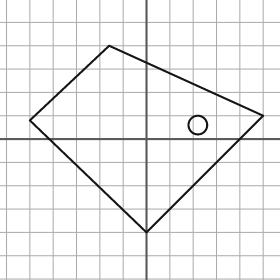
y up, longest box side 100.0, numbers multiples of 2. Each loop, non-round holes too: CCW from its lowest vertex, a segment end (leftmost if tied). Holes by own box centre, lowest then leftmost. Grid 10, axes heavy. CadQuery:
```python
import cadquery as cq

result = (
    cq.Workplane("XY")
    .moveTo(0.0, -40.0)
    .lineTo(50.0, 10.0)
    .lineTo(-16.0, 40.0)
    .lineTo(-50.0, 8.0)
    .close()
    .moveTo(22.0, 6.0)
    .circle(4.0)
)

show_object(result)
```